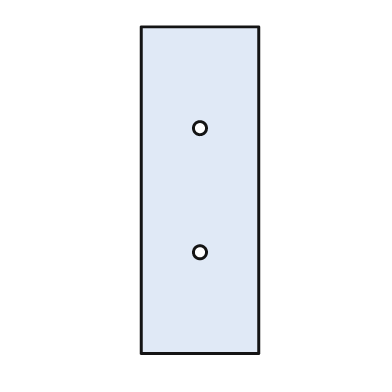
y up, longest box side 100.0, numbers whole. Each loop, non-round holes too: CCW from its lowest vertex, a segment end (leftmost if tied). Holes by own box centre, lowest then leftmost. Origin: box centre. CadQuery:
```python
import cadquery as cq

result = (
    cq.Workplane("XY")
    .moveTo(-18.0, -50.0)
    .lineTo(18.0, -50.0)
    .lineTo(18.0, 50.0)
    .lineTo(-18.0, 50.0)
    .close()
    .moveTo(0.0, -19.0)
    .circle(2.0)
    .moveTo(0.0, 19.0)
    .circle(2.0)
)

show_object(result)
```